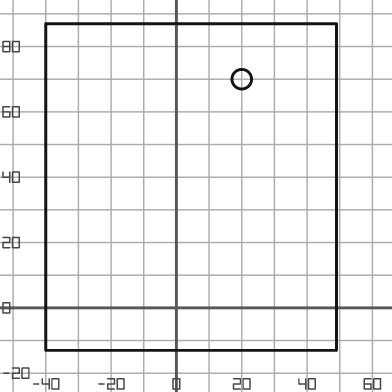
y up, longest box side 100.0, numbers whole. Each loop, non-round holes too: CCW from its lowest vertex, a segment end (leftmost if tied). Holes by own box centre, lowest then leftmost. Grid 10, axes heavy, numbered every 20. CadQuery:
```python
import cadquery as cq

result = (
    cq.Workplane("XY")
    .moveTo(-40.0, -13.0)
    .lineTo(49.0, -13.0)
    .lineTo(49.0, 87.0)
    .lineTo(-40.0, 87.0)
    .close()
    .moveTo(20.0, 70.0)
    .circle(3.0)
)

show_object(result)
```